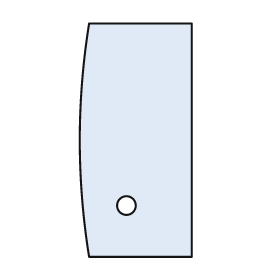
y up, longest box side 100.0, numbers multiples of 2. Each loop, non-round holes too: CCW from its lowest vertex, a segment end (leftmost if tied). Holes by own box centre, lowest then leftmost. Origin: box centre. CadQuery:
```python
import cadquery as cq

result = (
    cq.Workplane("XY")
    .moveTo(-20.0, -50.0)
    .lineTo(24.0, -50.0)
    .lineTo(24.0, 50.0)
    .lineTo(-20.0, 50.0)
    .threePointArc((-24.0, 0.0), (-20.0, -50.0))
    .close()
    .moveTo(-4.0, -28.0)
    .circle(4.0)
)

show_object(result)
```